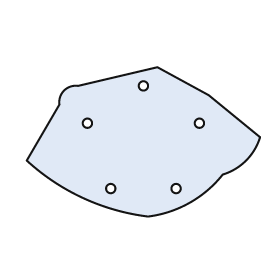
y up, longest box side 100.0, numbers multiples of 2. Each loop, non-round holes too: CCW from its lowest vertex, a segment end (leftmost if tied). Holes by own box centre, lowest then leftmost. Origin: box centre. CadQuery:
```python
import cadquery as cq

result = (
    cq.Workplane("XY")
    .moveTo(2.0, -32.0)
    .threePointArc((20.0, -26.0), (34.0, -14.0))
    .threePointArc((44.0, -8.0), (50.0, 2.0))
    .lineTo(28.0, 20.0)
    .lineTo(6.0, 32.0)
    .lineTo(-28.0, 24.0)
    .threePointArc((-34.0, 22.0), (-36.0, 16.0))
    .lineTo(-50.0, -8.0)
    .threePointArc((-26.0, -24.0), (2.0, -32.0))
    .close()
    .moveTo(-14.0, -20.0)
    .circle(2.0)
    .moveTo(14.0, -20.0)
    .circle(2.0)
    .moveTo(-24.0, 8.0)
    .circle(2.0)
    .moveTo(24.0, 8.0)
    .circle(2.0)
    .moveTo(0.0, 24.0)
    .circle(2.0)
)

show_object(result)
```